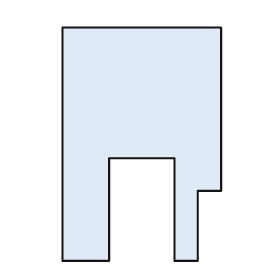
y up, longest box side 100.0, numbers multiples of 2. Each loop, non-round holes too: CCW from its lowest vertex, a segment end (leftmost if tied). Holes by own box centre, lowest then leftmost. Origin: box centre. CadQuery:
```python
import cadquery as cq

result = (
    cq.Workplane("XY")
    .moveTo(-34.0, -50.0)
    .lineTo(-14.0, -50.0)
    .lineTo(-14.0, -6.0)
    .lineTo(14.0, -6.0)
    .lineTo(14.0, -50.0)
    .lineTo(24.0, -50.0)
    .lineTo(24.0, -20.0)
    .lineTo(34.0, -20.0)
    .lineTo(34.0, 50.0)
    .lineTo(-34.0, 50.0)
    .close()
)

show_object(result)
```